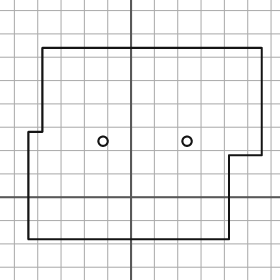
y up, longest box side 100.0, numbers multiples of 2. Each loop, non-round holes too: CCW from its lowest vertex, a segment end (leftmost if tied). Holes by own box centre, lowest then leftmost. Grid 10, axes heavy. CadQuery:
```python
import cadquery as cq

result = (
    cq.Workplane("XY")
    .moveTo(-44.0, -18.0)
    .lineTo(42.0, -18.0)
    .lineTo(42.0, 18.0)
    .lineTo(56.0, 18.0)
    .lineTo(56.0, 64.0)
    .lineTo(-38.0, 64.0)
    .lineTo(-38.0, 28.0)
    .lineTo(-44.0, 28.0)
    .close()
    .moveTo(-12.0, 24.0)
    .circle(2.0)
    .moveTo(24.0, 24.0)
    .circle(2.0)
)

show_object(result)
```